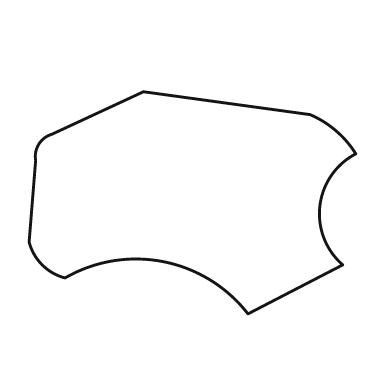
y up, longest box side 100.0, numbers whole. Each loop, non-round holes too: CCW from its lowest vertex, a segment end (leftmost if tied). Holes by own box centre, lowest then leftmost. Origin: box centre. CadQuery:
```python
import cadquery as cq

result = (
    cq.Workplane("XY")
    .moveTo(17.0, -34.0)
    .lineTo(46.0, -19.0)
    .threePointArc((39.0, -1.0), (50.0, 15.0))
    .threePointArc((44.0, 22.0), (36.0, 27.0))
    .lineTo(-15.0, 34.0)
    .lineTo(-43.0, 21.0)
    .threePointArc((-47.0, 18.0), (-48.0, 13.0))
    .lineTo(-50.0, -12.0)
    .threePointArc((-46.0, -19.0), (-39.0, -23.0))
    .threePointArc((-9.0, -18.0), (17.0, -34.0))
    .close()
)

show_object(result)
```